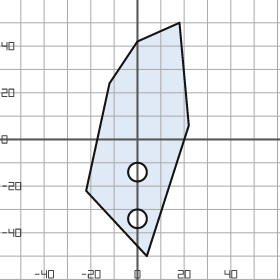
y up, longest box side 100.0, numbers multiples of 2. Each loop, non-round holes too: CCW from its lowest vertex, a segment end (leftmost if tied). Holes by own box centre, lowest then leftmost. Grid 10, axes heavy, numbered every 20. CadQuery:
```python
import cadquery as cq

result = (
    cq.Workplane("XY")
    .moveTo(4.0, -50.0)
    .lineTo(22.0, 6.0)
    .lineTo(18.0, 50.0)
    .lineTo(0.0, 42.0)
    .lineTo(-12.0, 24.0)
    .lineTo(-22.0, -22.0)
    .close()
    .moveTo(0.0, -34.0)
    .circle(4.0)
    .moveTo(0.0, -14.0)
    .circle(4.0)
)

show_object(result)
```